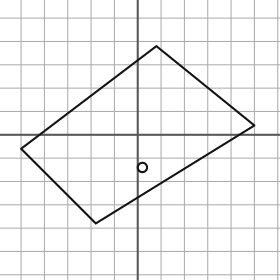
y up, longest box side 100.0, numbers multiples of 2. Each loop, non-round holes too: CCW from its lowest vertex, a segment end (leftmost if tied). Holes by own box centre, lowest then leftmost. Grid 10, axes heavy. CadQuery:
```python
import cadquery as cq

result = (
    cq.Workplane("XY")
    .moveTo(-18.0, -38.0)
    .lineTo(50.0, 4.0)
    .lineTo(8.0, 38.0)
    .lineTo(-50.0, -6.0)
    .close()
    .moveTo(2.0, -14.0)
    .circle(2.0)
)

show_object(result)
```